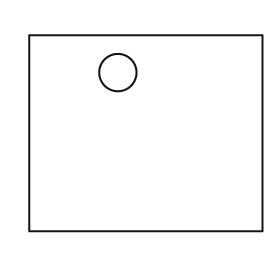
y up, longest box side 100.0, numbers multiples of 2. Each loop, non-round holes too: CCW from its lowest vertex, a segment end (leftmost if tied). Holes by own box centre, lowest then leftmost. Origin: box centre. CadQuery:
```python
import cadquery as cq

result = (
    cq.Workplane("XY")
    .moveTo(-50.0, -42.0)
    .lineTo(50.0, -42.0)
    .lineTo(50.0, 42.0)
    .lineTo(-50.0, 42.0)
    .close()
    .moveTo(-12.0, 26.0)
    .circle(8.0)
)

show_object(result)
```